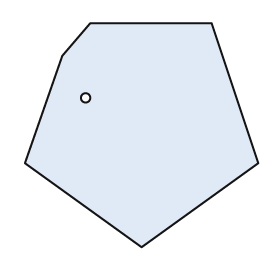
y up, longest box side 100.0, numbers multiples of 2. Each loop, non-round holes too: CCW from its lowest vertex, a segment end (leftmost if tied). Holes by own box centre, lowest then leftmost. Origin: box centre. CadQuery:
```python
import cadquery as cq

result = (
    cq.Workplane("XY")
    .moveTo(0.0, -48.0)
    .lineTo(50.0, -12.0)
    .lineTo(30.0, 48.0)
    .lineTo(-22.0, 48.0)
    .lineTo(-34.0, 34.0)
    .lineTo(-50.0, -12.0)
    .close()
    .moveTo(-24.0, 16.0)
    .circle(2.0)
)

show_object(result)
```